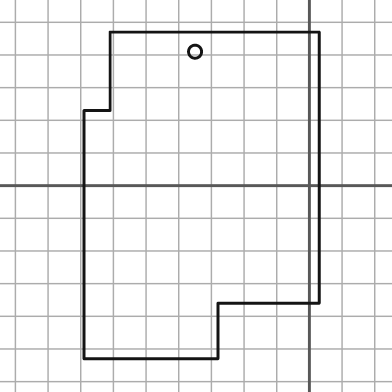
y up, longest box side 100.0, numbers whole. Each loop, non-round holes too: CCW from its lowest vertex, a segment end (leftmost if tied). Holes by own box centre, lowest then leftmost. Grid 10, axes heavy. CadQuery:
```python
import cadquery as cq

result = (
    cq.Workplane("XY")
    .moveTo(-69.0, -53.0)
    .lineTo(-28.0, -53.0)
    .lineTo(-28.0, -36.0)
    .lineTo(3.0, -36.0)
    .lineTo(3.0, 47.0)
    .lineTo(-61.0, 47.0)
    .lineTo(-61.0, 23.0)
    .lineTo(-69.0, 23.0)
    .close()
    .moveTo(-35.0, 41.0)
    .circle(2.0)
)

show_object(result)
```